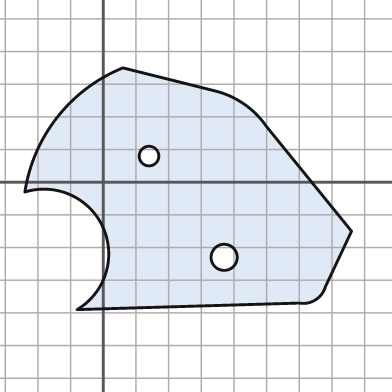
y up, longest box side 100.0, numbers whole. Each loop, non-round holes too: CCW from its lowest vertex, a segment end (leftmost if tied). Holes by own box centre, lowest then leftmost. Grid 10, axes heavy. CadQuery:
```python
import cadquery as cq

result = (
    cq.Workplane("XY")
    .moveTo(-8.0, -39.0)
    .lineTo(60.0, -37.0)
    .threePointArc((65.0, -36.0), (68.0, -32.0))
    .lineTo(76.0, -15.0)
    .lineTo(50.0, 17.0)
    .threePointArc((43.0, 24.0), (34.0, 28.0))
    .lineTo(6.0, 35.0)
    .threePointArc((-14.0, 20.0), (-24.0, -3.0))
    .threePointArc((0.0, -14.0), (-8.0, -39.0))
    .close()
    .moveTo(37.0, -23.0)
    .circle(4.0)
    .moveTo(14.0, 8.0)
    .circle(3.0)
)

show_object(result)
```